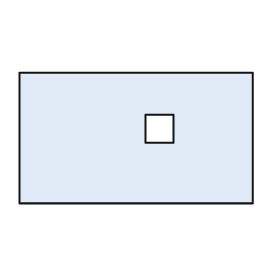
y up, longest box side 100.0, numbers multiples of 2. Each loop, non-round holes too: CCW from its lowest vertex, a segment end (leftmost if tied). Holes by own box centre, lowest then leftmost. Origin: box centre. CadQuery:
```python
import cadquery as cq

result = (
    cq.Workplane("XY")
    .moveTo(-50.0, -28.0)
    .lineTo(50.0, -28.0)
    .lineTo(50.0, 28.0)
    .lineTo(-50.0, 28.0)
    .close()
    .moveTo(4.0, -2.0)
    .lineTo(16.0, -2.0)
    .lineTo(16.0, 10.0)
    .lineTo(4.0, 10.0)
    .close()
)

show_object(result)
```